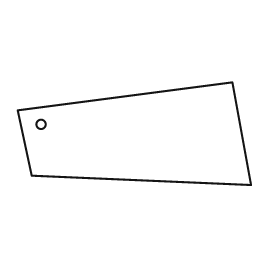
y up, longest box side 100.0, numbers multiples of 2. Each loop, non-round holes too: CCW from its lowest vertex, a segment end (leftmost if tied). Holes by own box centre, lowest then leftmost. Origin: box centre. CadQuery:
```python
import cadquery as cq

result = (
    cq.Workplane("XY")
    .moveTo(50.0, -22.0)
    .lineTo(42.0, 22.0)
    .lineTo(-50.0, 10.0)
    .lineTo(-44.0, -18.0)
    .close()
    .moveTo(-40.0, 4.0)
    .circle(2.0)
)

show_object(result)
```